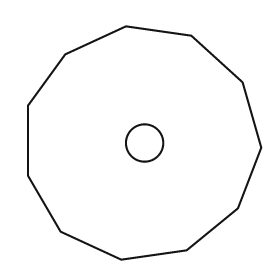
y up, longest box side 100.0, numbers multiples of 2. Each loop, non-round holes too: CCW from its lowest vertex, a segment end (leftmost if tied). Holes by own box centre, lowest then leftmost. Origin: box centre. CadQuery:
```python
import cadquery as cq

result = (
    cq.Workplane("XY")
    .moveTo(-10.0, -50.0)
    .lineTo(18.0, -46.0)
    .lineTo(40.0, -28.0)
    .lineTo(50.0, -2.0)
    .lineTo(42.0, 26.0)
    .lineTo(20.0, 46.0)
    .lineTo(-8.0, 50.0)
    .lineTo(-34.0, 38.0)
    .lineTo(-50.0, 16.0)
    .lineTo(-50.0, -14.0)
    .lineTo(-36.0, -38.0)
    .close()
    .moveTo(0.0, 0.0)
    .circle(8.0)
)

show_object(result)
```